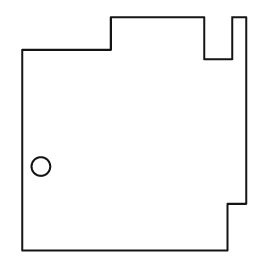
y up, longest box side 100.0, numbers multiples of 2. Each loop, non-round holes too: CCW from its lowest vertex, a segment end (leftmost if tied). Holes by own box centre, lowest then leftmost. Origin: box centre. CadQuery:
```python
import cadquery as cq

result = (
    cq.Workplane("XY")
    .moveTo(-48.0, -50.0)
    .lineTo(40.0, -50.0)
    .lineTo(40.0, -30.0)
    .lineTo(48.0, -30.0)
    .lineTo(48.0, 50.0)
    .lineTo(42.0, 50.0)
    .lineTo(42.0, 32.0)
    .lineTo(30.0, 32.0)
    .lineTo(30.0, 50.0)
    .lineTo(-10.0, 50.0)
    .lineTo(-10.0, 36.0)
    .lineTo(-48.0, 36.0)
    .close()
    .moveTo(-40.0, -14.0)
    .circle(4.0)
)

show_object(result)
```